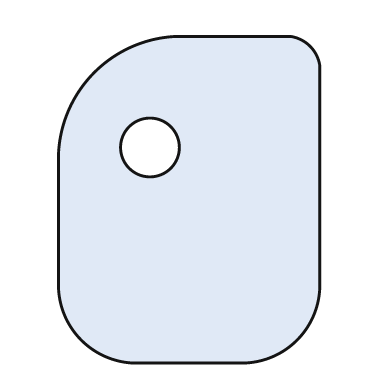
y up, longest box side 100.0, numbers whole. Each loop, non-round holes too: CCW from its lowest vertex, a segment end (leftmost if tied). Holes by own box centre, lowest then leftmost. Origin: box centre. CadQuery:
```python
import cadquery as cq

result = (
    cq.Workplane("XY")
    .moveTo(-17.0, -50.0)
    .lineTo(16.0, -50.0)
    .threePointArc((33.0, -43.0), (40.0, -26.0))
    .lineTo(40.0, 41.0)
    .threePointArc((37.0, 47.0), (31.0, 50.0))
    .lineTo(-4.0, 50.0)
    .threePointArc((-29.0, 39.0), (-40.0, 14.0))
    .lineTo(-40.0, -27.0)
    .threePointArc((-33.0, -43.0), (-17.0, -50.0))
    .close()
    .moveTo(-12.0, 16.0)
    .circle(9.0)
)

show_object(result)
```